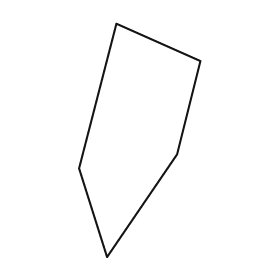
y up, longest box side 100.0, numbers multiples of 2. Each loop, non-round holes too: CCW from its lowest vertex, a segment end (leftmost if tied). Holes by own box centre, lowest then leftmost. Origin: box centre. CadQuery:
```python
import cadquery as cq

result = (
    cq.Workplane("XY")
    .moveTo(-14.0, -50.0)
    .lineTo(16.0, -6.0)
    .lineTo(26.0, 34.0)
    .lineTo(-10.0, 50.0)
    .lineTo(-26.0, -12.0)
    .close()
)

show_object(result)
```